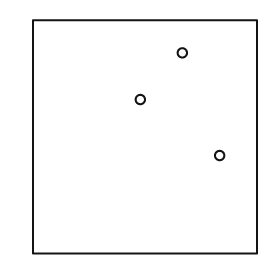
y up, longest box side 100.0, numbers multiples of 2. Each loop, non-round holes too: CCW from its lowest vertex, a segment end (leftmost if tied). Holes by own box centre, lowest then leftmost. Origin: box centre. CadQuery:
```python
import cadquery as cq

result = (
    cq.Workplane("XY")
    .moveTo(-48.0, -50.0)
    .lineTo(48.0, -50.0)
    .lineTo(48.0, 50.0)
    .lineTo(-48.0, 50.0)
    .close()
    .moveTo(32.0, -8.0)
    .circle(2.0)
    .moveTo(-2.0, 16.0)
    .circle(2.0)
    .moveTo(16.0, 36.0)
    .circle(2.0)
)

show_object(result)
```